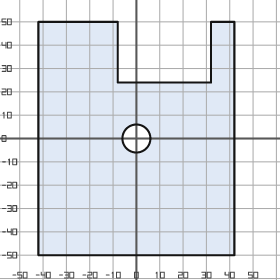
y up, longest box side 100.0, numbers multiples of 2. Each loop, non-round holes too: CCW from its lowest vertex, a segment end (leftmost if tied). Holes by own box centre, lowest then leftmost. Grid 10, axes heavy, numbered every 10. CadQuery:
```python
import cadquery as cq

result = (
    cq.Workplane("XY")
    .moveTo(-42.0, -50.0)
    .lineTo(42.0, -50.0)
    .lineTo(42.0, 50.0)
    .lineTo(32.0, 50.0)
    .lineTo(32.0, 24.0)
    .lineTo(-8.0, 24.0)
    .lineTo(-8.0, 50.0)
    .lineTo(-42.0, 50.0)
    .close()
    .moveTo(0.0, 0.0)
    .circle(6.0)
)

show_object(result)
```